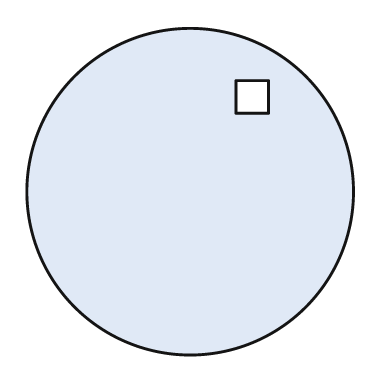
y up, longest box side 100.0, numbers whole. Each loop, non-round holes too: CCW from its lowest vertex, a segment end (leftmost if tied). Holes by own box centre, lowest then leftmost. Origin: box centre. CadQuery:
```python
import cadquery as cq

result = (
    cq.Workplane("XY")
    .moveTo(0.0, 0.0)
    .circle(50.0)
    .moveTo(14.0, 24.0)
    .lineTo(24.0, 24.0)
    .lineTo(24.0, 34.0)
    .lineTo(14.0, 34.0)
    .close()
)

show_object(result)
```